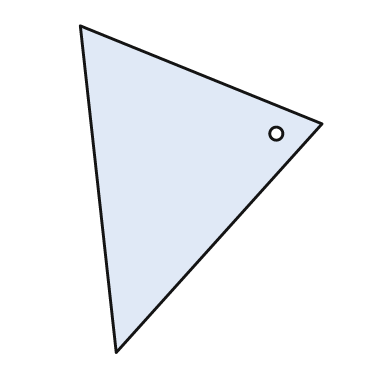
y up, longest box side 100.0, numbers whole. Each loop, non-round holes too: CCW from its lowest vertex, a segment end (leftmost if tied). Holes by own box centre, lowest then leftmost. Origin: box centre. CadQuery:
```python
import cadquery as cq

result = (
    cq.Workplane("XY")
    .moveTo(-26.0, -50.0)
    .lineTo(37.0, 20.0)
    .lineTo(-37.0, 50.0)
    .close()
    .moveTo(23.0, 17.0)
    .circle(2.0)
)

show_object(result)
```